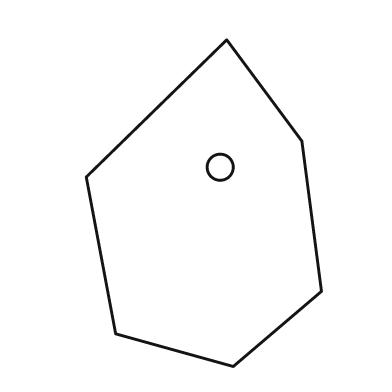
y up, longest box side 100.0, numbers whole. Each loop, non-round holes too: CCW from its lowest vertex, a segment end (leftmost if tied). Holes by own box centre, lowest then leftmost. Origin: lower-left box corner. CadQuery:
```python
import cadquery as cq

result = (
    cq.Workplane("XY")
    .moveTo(45.0, 0.0)
    .lineTo(72.0, 23.0)
    .lineTo(66.0, 69.0)
    .lineTo(43.0, 100.0)
    .lineTo(0.0, 58.0)
    .lineTo(9.0, 10.0)
    .close()
    .moveTo(41.0, 61.0)
    .circle(4.0)
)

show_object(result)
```